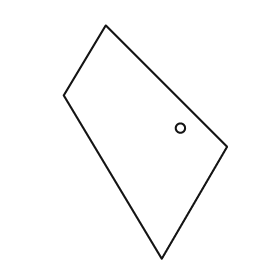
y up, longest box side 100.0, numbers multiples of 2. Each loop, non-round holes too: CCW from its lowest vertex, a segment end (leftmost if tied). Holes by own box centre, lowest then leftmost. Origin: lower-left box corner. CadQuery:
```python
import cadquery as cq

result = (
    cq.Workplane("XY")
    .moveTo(42.0, 0.0)
    .lineTo(70.0, 48.0)
    .lineTo(18.0, 100.0)
    .lineTo(0.0, 70.0)
    .close()
    .moveTo(50.0, 56.0)
    .circle(2.0)
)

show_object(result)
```